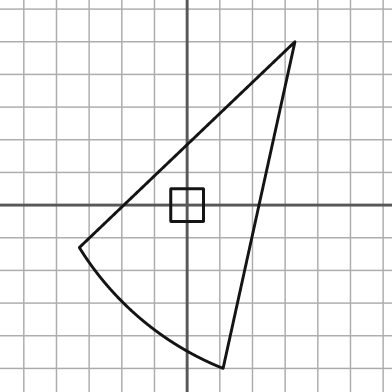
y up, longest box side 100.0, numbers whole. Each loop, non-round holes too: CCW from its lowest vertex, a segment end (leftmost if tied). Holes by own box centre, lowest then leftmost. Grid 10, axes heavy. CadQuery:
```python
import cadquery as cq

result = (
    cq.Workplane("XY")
    .moveTo(11.0, -50.0)
    .lineTo(33.0, 50.0)
    .lineTo(-33.0, -13.0)
    .threePointArc((-14.0, -35.0), (11.0, -50.0))
    .close()
    .moveTo(-5.0, -5.0)
    .lineTo(5.0, -5.0)
    .lineTo(5.0, 5.0)
    .lineTo(-5.0, 5.0)
    .close()
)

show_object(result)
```